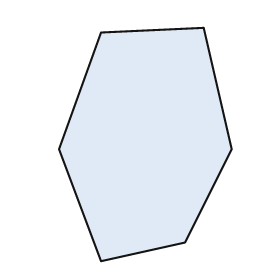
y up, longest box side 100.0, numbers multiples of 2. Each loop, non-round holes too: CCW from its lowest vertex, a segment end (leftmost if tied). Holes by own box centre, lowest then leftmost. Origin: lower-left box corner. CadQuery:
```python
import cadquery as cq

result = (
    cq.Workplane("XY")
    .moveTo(18.0, 0.0)
    .lineTo(54.0, 8.0)
    .lineTo(74.0, 48.0)
    .lineTo(62.0, 100.0)
    .lineTo(18.0, 98.0)
    .lineTo(0.0, 48.0)
    .close()
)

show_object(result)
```